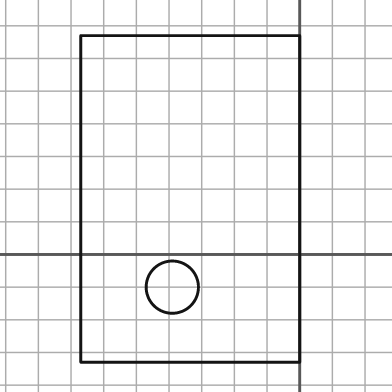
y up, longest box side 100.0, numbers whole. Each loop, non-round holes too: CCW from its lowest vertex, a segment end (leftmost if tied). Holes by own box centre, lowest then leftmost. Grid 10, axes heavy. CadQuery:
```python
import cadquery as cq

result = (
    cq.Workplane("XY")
    .moveTo(-67.0, -33.0)
    .lineTo(0.0, -33.0)
    .lineTo(0.0, 67.0)
    .lineTo(-67.0, 67.0)
    .close()
    .moveTo(-39.0, -10.0)
    .circle(8.0)
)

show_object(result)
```